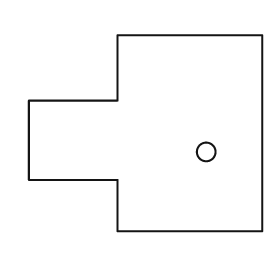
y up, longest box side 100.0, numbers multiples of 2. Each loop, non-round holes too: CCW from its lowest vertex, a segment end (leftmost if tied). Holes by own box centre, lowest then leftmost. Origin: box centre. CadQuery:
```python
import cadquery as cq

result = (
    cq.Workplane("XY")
    .moveTo(-12.0, -42.0)
    .lineTo(50.0, -42.0)
    .lineTo(50.0, 42.0)
    .lineTo(-12.0, 42.0)
    .lineTo(-12.0, 14.0)
    .lineTo(-50.0, 14.0)
    .lineTo(-50.0, -20.0)
    .lineTo(-12.0, -20.0)
    .close()
    .moveTo(26.0, -8.0)
    .circle(4.0)
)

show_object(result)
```